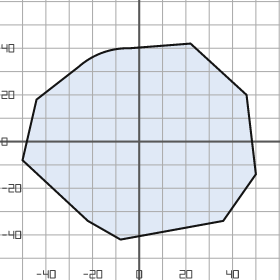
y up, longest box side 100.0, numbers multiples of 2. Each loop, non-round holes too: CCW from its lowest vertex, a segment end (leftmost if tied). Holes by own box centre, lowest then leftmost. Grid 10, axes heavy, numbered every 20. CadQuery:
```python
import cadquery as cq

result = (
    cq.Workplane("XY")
    .moveTo(-8.0, -42.0)
    .lineTo(36.0, -34.0)
    .lineTo(50.0, -14.0)
    .lineTo(46.0, 20.0)
    .lineTo(22.0, 42.0)
    .lineTo(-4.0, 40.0)
    .threePointArc((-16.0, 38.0), (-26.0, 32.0))
    .lineTo(-44.0, 18.0)
    .lineTo(-50.0, -8.0)
    .lineTo(-22.0, -34.0)
    .close()
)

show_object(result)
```